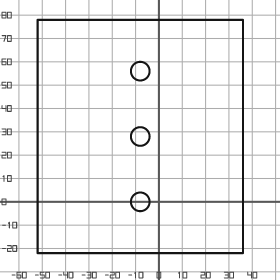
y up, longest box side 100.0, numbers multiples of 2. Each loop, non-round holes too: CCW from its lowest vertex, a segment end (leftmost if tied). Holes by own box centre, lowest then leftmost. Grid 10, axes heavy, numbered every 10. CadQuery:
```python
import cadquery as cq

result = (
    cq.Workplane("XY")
    .moveTo(-52.0, -22.0)
    .lineTo(36.0, -22.0)
    .lineTo(36.0, 78.0)
    .lineTo(-52.0, 78.0)
    .close()
    .moveTo(-8.0, 0.0)
    .circle(4.0)
    .moveTo(-8.0, 28.0)
    .circle(4.0)
    .moveTo(-8.0, 56.0)
    .circle(4.0)
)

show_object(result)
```